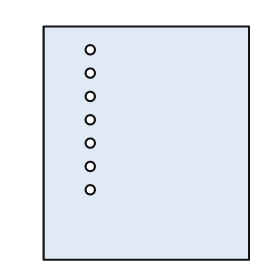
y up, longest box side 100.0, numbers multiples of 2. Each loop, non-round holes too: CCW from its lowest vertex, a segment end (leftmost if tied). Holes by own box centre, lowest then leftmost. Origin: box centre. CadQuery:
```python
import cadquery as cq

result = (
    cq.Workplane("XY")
    .moveTo(-44.0, -50.0)
    .lineTo(44.0, -50.0)
    .lineTo(44.0, 50.0)
    .lineTo(-44.0, 50.0)
    .close()
    .moveTo(-24.0, -20.0)
    .circle(2.0)
    .moveTo(-24.0, -10.0)
    .circle(2.0)
    .moveTo(-24.0, 0.0)
    .circle(2.0)
    .moveTo(-24.0, 10.0)
    .circle(2.0)
    .moveTo(-24.0, 20.0)
    .circle(2.0)
    .moveTo(-24.0, 30.0)
    .circle(2.0)
    .moveTo(-24.0, 40.0)
    .circle(2.0)
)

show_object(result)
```